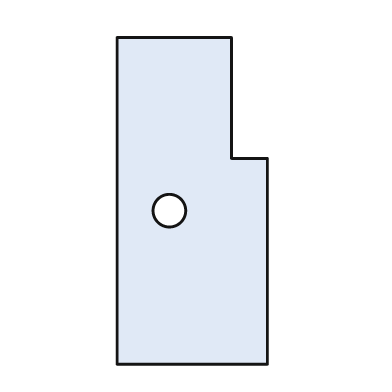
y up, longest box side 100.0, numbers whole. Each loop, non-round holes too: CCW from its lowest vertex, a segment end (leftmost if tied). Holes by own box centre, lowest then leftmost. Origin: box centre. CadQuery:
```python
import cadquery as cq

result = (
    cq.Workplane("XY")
    .moveTo(-23.0, -50.0)
    .lineTo(23.0, -50.0)
    .lineTo(23.0, 13.0)
    .lineTo(12.0, 13.0)
    .lineTo(12.0, 50.0)
    .lineTo(-23.0, 50.0)
    .close()
    .moveTo(-7.0, -3.0)
    .circle(5.0)
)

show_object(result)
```